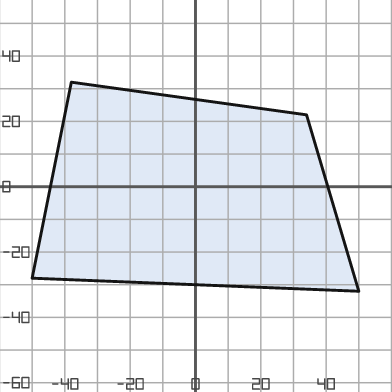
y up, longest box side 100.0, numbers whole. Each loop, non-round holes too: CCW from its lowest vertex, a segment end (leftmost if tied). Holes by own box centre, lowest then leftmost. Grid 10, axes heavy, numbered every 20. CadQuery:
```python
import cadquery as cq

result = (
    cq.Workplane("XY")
    .moveTo(50.0, -32.0)
    .lineTo(34.0, 22.0)
    .lineTo(-38.0, 32.0)
    .lineTo(-50.0, -28.0)
    .close()
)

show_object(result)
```